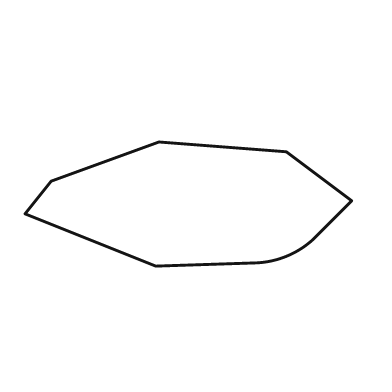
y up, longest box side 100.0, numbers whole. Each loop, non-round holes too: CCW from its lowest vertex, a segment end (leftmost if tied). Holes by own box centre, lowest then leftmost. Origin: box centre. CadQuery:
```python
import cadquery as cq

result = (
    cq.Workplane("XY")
    .moveTo(-10.0, -19.0)
    .lineTo(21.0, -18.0)
    .threePointArc((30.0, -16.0), (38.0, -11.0))
    .lineTo(50.0, 1.0)
    .lineTo(30.0, 16.0)
    .lineTo(-9.0, 19.0)
    .lineTo(-42.0, 7.0)
    .lineTo(-50.0, -3.0)
    .close()
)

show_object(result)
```